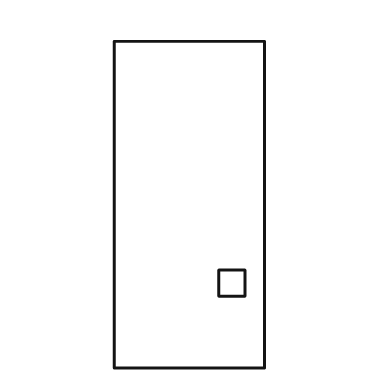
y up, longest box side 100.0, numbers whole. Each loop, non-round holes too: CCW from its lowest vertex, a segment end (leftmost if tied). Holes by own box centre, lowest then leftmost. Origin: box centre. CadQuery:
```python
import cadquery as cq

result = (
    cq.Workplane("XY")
    .moveTo(-23.0, -50.0)
    .lineTo(23.0, -50.0)
    .lineTo(23.0, 50.0)
    .lineTo(-23.0, 50.0)
    .close()
    .moveTo(9.0, -28.0)
    .lineTo(17.0, -28.0)
    .lineTo(17.0, -20.0)
    .lineTo(9.0, -20.0)
    .close()
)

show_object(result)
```